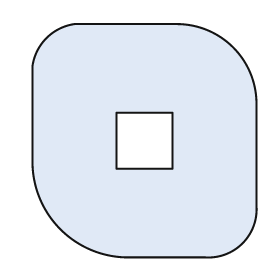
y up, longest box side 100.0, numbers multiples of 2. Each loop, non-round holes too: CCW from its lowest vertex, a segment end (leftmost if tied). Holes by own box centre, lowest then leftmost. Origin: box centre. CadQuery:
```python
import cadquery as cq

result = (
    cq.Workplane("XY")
    .moveTo(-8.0, -50.0)
    .lineTo(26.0, -50.0)
    .threePointArc((42.0, -44.0), (48.0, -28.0))
    .lineTo(48.0, 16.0)
    .threePointArc((38.0, 40.0), (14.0, 50.0))
    .lineTo(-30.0, 50.0)
    .threePointArc((-42.0, 44.0), (-48.0, 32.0))
    .lineTo(-48.0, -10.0)
    .threePointArc((-36.0, -38.0), (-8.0, -50.0))
    .close()
    .moveTo(-12.0, -12.0)
    .lineTo(12.0, -12.0)
    .lineTo(12.0, 12.0)
    .lineTo(-12.0, 12.0)
    .close()
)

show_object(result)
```